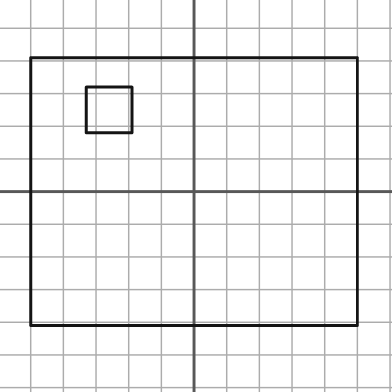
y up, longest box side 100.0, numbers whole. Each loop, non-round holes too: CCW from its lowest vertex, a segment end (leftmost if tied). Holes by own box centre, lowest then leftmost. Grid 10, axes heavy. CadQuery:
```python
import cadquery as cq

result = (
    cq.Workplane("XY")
    .moveTo(-50.0, -41.0)
    .lineTo(50.0, -41.0)
    .lineTo(50.0, 41.0)
    .lineTo(-50.0, 41.0)
    .close()
    .moveTo(-33.0, 18.0)
    .lineTo(-19.0, 18.0)
    .lineTo(-19.0, 32.0)
    .lineTo(-33.0, 32.0)
    .close()
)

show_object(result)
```